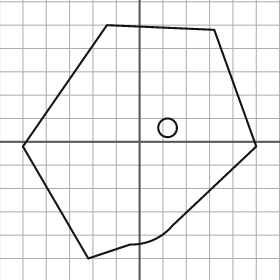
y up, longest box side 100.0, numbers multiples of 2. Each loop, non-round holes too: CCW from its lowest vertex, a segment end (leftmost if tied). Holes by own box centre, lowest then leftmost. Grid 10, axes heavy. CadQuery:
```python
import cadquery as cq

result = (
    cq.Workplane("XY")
    .moveTo(-22.0, -50.0)
    .lineTo(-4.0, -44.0)
    .threePointArc((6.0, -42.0), (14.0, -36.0))
    .lineTo(50.0, -2.0)
    .lineTo(32.0, 48.0)
    .lineTo(-14.0, 50.0)
    .lineTo(-50.0, -2.0)
    .close()
    .moveTo(12.0, 6.0)
    .circle(4.0)
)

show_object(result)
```